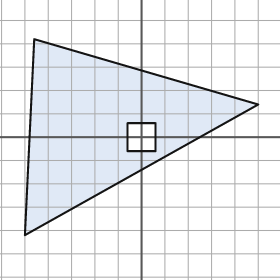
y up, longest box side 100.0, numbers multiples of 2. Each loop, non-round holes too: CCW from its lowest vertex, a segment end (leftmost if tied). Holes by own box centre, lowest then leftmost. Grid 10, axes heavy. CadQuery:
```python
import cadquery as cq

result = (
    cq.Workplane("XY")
    .moveTo(-50.0, -42.0)
    .lineTo(50.0, 14.0)
    .lineTo(-46.0, 42.0)
    .close()
    .moveTo(-6.0, -6.0)
    .lineTo(6.0, -6.0)
    .lineTo(6.0, 6.0)
    .lineTo(-6.0, 6.0)
    .close()
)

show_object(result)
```